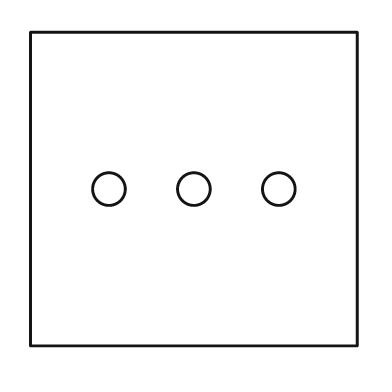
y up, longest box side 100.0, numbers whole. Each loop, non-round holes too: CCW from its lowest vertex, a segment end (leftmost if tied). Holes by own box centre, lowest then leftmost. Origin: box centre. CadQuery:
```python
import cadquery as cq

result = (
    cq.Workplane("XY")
    .moveTo(-50.0, -48.0)
    .lineTo(50.0, -48.0)
    .lineTo(50.0, 48.0)
    .lineTo(-50.0, 48.0)
    .close()
    .moveTo(-26.0, 0.0)
    .circle(5.0)
    .moveTo(0.0, 0.0)
    .circle(5.0)
    .moveTo(26.0, 0.0)
    .circle(5.0)
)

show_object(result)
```